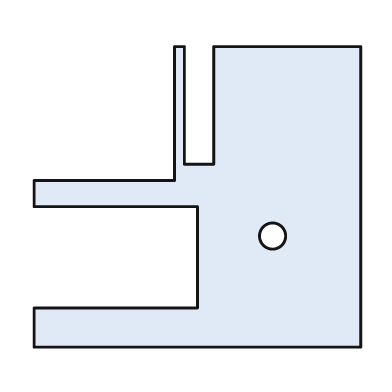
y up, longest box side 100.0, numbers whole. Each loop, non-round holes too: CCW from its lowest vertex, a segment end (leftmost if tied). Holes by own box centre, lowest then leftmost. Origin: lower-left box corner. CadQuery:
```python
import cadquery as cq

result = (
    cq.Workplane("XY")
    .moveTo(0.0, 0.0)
    .lineTo(100.0, 0.0)
    .lineTo(100.0, 92.0)
    .lineTo(55.0, 92.0)
    .lineTo(55.0, 56.0)
    .lineTo(46.0, 56.0)
    .lineTo(46.0, 92.0)
    .lineTo(43.0, 92.0)
    .lineTo(43.0, 51.0)
    .lineTo(0.0, 51.0)
    .lineTo(0.0, 43.0)
    .lineTo(50.0, 43.0)
    .lineTo(50.0, 12.0)
    .lineTo(0.0, 12.0)
    .close()
    .moveTo(73.0, 34.0)
    .circle(4.0)
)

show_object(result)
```